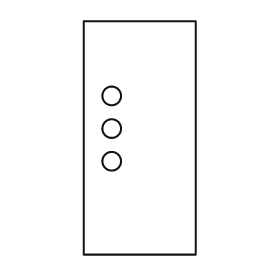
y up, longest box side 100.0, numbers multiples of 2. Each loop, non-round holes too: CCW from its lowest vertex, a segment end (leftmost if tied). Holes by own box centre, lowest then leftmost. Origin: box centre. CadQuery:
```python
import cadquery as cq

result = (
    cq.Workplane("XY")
    .moveTo(-24.0, -50.0)
    .lineTo(24.0, -50.0)
    .lineTo(24.0, 50.0)
    .lineTo(-24.0, 50.0)
    .close()
    .moveTo(-12.0, -10.0)
    .circle(4.0)
    .moveTo(-12.0, 4.0)
    .circle(4.0)
    .moveTo(-12.0, 18.0)
    .circle(4.0)
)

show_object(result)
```